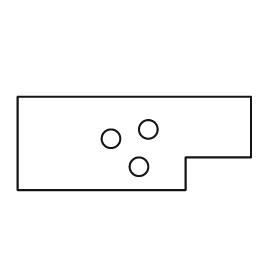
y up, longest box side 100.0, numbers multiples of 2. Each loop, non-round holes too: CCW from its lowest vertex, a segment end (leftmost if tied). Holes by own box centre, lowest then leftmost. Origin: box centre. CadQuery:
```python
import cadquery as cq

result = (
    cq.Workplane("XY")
    .moveTo(-50.0, -20.0)
    .lineTo(22.0, -20.0)
    .lineTo(22.0, -6.0)
    .lineTo(50.0, -6.0)
    .lineTo(50.0, 20.0)
    .lineTo(-50.0, 20.0)
    .close()
    .moveTo(2.0, -10.0)
    .circle(4.0)
    .moveTo(-10.0, 2.0)
    .circle(4.0)
    .moveTo(6.0, 6.0)
    .circle(4.0)
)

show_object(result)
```